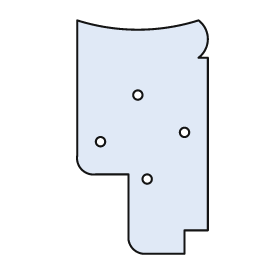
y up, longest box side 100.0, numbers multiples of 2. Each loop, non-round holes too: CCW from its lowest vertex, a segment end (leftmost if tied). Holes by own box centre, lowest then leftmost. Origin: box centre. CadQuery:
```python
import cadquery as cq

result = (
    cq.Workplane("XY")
    .moveTo(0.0, -50.0)
    .lineTo(18.0, -50.0)
    .lineTo(18.0, -40.0)
    .lineTo(28.0, -40.0)
    .lineTo(28.0, 34.0)
    .lineTo(24.0, 34.0)
    .threePointArc((28.0, 42.0), (24.0, 50.0))
    .threePointArc((-2.0, 46.0), (-28.0, 50.0))
    .lineTo(-28.0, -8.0)
    .threePointArc((-26.0, -14.0), (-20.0, -16.0))
    .lineTo(-6.0, -16.0)
    .lineTo(-6.0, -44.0)
    .threePointArc((-4.0, -48.0), (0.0, -50.0))
    .close()
    .moveTo(2.0, -18.0)
    .circle(2.0)
    .moveTo(-18.0, -2.0)
    .circle(2.0)
    .moveTo(18.0, 2.0)
    .circle(2.0)
    .moveTo(-2.0, 18.0)
    .circle(2.0)
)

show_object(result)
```